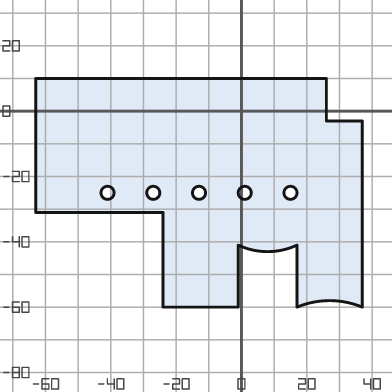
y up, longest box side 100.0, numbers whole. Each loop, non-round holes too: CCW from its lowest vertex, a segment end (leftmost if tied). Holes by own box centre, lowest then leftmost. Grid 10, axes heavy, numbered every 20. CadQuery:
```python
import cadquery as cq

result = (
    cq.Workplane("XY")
    .moveTo(-24.0, -60.0)
    .lineTo(-1.0, -60.0)
    .lineTo(-1.0, -41.0)
    .threePointArc((8.0, -43.0), (17.0, -41.0))
    .lineTo(17.0, -60.0)
    .threePointArc((27.0, -58.0), (37.0, -60.0))
    .lineTo(37.0, -3.0)
    .lineTo(26.0, -3.0)
    .lineTo(26.0, 10.0)
    .lineTo(-63.0, 10.0)
    .lineTo(-63.0, -31.0)
    .lineTo(-24.0, -31.0)
    .close()
    .moveTo(-41.0, -25.0)
    .circle(2.0)
    .moveTo(-27.0, -25.0)
    .circle(2.0)
    .moveTo(-13.0, -25.0)
    .circle(2.0)
    .moveTo(1.0, -25.0)
    .circle(2.0)
    .moveTo(15.0, -25.0)
    .circle(2.0)
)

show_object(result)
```